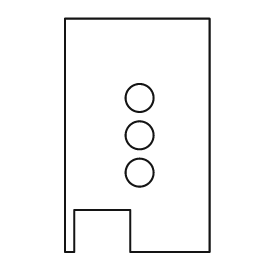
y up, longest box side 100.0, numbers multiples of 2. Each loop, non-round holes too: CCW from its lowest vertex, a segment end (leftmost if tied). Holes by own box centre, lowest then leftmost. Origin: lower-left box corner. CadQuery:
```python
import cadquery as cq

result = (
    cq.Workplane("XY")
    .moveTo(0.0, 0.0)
    .lineTo(4.0, 0.0)
    .lineTo(4.0, 18.0)
    .lineTo(28.0, 18.0)
    .lineTo(28.0, 0.0)
    .lineTo(62.0, 0.0)
    .lineTo(62.0, 100.0)
    .lineTo(0.0, 100.0)
    .close()
    .moveTo(32.0, 34.0)
    .circle(6.0)
    .moveTo(32.0, 50.0)
    .circle(6.0)
    .moveTo(32.0, 66.0)
    .circle(6.0)
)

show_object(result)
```